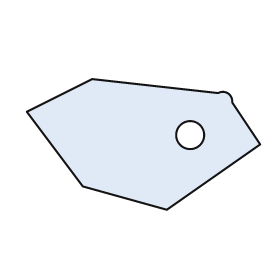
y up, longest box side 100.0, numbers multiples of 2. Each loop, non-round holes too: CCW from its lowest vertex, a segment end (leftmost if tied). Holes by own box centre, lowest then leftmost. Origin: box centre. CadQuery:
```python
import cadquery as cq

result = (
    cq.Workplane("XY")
    .moveTo(10.0, -28.0)
    .lineTo(50.0, 0.0)
    .lineTo(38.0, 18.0)
    .threePointArc((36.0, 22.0), (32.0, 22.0))
    .lineTo(-22.0, 28.0)
    .lineTo(-50.0, 14.0)
    .lineTo(-26.0, -18.0)
    .close()
    .moveTo(20.0, 4.0)
    .circle(6.0)
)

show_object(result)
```